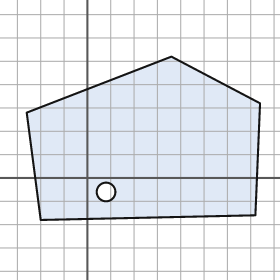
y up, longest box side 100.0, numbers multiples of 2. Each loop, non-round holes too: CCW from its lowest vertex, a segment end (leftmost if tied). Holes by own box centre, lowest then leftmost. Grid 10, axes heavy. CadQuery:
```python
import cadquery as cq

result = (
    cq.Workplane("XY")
    .moveTo(-20.0, -18.0)
    .lineTo(72.0, -16.0)
    .lineTo(74.0, 32.0)
    .lineTo(36.0, 52.0)
    .lineTo(-26.0, 28.0)
    .close()
    .moveTo(8.0, -6.0)
    .circle(4.0)
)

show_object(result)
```